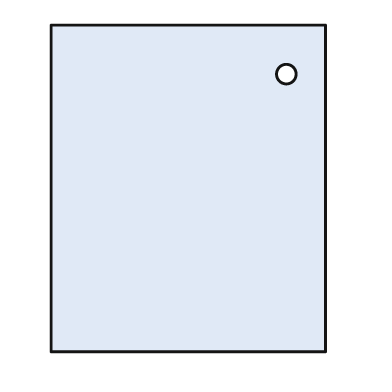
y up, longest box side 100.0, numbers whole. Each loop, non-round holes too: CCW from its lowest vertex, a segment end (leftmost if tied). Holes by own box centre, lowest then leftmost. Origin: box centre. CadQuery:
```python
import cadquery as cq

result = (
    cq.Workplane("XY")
    .moveTo(-42.0, -50.0)
    .lineTo(42.0, -50.0)
    .lineTo(42.0, 50.0)
    .lineTo(-42.0, 50.0)
    .close()
    .moveTo(30.0, 35.0)
    .circle(3.0)
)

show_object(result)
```